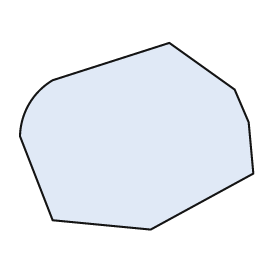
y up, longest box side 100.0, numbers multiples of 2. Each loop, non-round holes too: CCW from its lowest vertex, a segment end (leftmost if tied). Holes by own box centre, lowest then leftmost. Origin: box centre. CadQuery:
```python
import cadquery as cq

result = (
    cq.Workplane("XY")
    .moveTo(6.0, -40.0)
    .lineTo(50.0, -16.0)
    .lineTo(48.0, 6.0)
    .lineTo(42.0, 20.0)
    .lineTo(14.0, 40.0)
    .lineTo(-36.0, 24.0)
    .threePointArc((-46.0, 14.0), (-50.0, 0.0))
    .lineTo(-36.0, -36.0)
    .close()
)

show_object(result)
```